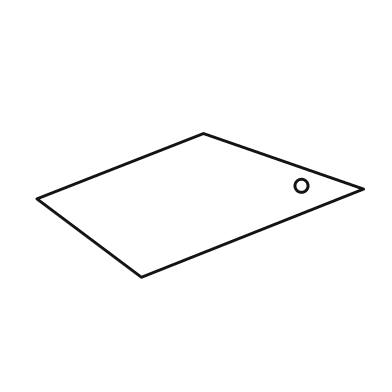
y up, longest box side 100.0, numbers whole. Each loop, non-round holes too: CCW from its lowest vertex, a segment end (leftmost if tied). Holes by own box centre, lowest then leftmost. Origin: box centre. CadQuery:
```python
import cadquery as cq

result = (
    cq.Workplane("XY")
    .moveTo(-18.0, -22.0)
    .lineTo(50.0, 5.0)
    .lineTo(1.0, 22.0)
    .lineTo(-50.0, 2.0)
    .close()
    .moveTo(31.0, 6.0)
    .circle(2.0)
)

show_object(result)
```